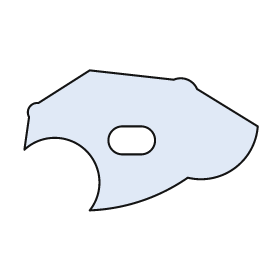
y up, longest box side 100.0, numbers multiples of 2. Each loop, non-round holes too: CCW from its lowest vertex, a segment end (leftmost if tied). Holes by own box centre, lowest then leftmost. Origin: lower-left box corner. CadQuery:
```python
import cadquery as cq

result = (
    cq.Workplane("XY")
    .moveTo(28.0, 0.0)
    .threePointArc((50.0, 4.0), (70.0, 14.0))
    .threePointArc((90.0, 18.0), (100.0, 36.0))
    .lineTo(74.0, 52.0)
    .threePointArc((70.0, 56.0), (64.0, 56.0))
    .lineTo(28.0, 60.0)
    .lineTo(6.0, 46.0)
    .threePointArc((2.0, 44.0), (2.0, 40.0))
    .lineTo(0.0, 26.0)
    .threePointArc((26.0, 26.0), (28.0, 0.0))
    .close()
    .moveTo(42.0, 24.0)
    .lineTo(50.0, 24.0)
    .threePointArc((56.0, 30.0), (50.0, 36.0))
    .lineTo(42.0, 36.0)
    .threePointArc((36.0, 30.0), (42.0, 24.0))
    .close()
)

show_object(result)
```